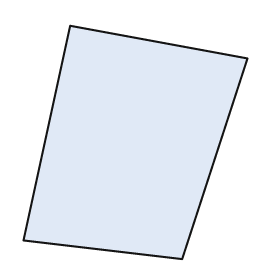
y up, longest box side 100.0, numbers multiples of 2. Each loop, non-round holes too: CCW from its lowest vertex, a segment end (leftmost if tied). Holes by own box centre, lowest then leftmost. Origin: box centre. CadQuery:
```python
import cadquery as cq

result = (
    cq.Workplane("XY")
    .moveTo(20.0, -50.0)
    .lineTo(48.0, 36.0)
    .lineTo(-28.0, 50.0)
    .lineTo(-48.0, -42.0)
    .close()
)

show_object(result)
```